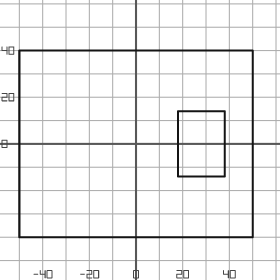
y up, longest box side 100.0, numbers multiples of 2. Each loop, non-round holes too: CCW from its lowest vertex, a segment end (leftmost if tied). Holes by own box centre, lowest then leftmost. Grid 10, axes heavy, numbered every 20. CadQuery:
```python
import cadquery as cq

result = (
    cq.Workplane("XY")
    .moveTo(-50.0, -40.0)
    .lineTo(50.0, -40.0)
    .lineTo(50.0, 40.0)
    .lineTo(-50.0, 40.0)
    .close()
    .moveTo(18.0, -14.0)
    .lineTo(38.0, -14.0)
    .lineTo(38.0, 14.0)
    .lineTo(18.0, 14.0)
    .close()
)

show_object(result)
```